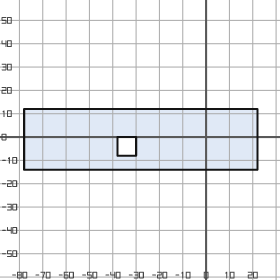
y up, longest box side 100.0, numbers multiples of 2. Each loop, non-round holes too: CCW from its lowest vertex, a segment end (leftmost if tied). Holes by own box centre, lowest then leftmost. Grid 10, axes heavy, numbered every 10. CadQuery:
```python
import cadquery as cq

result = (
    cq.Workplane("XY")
    .moveTo(-78.0, -14.0)
    .lineTo(22.0, -14.0)
    .lineTo(22.0, 12.0)
    .lineTo(-78.0, 12.0)
    .close()
    .moveTo(-38.0, -8.0)
    .lineTo(-30.0, -8.0)
    .lineTo(-30.0, 0.0)
    .lineTo(-38.0, 0.0)
    .close()
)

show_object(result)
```